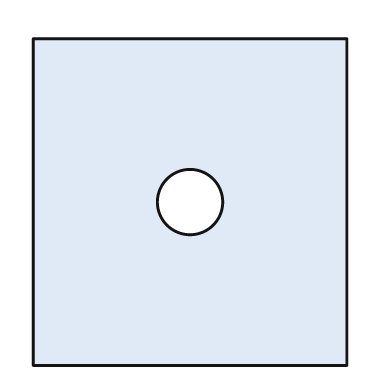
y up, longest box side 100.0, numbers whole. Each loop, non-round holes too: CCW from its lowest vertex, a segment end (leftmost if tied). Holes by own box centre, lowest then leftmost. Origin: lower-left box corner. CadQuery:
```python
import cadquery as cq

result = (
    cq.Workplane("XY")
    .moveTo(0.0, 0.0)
    .lineTo(96.0, 0.0)
    .lineTo(96.0, 100.0)
    .lineTo(0.0, 100.0)
    .close()
    .moveTo(48.0, 50.0)
    .circle(10.0)
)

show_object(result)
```